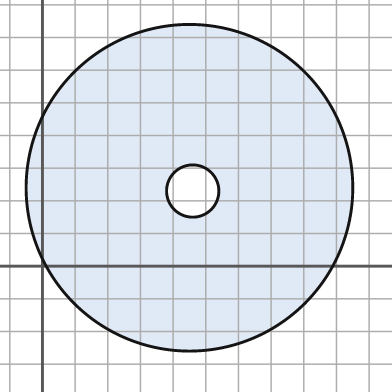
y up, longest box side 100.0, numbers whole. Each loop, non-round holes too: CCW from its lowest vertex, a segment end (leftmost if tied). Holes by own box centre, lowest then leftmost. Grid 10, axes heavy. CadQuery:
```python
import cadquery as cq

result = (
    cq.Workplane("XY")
    .moveTo(45.0, 24.0)
    .circle(50.0)
    .moveTo(46.0, 23.0)
    .circle(8.0)
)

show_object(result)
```